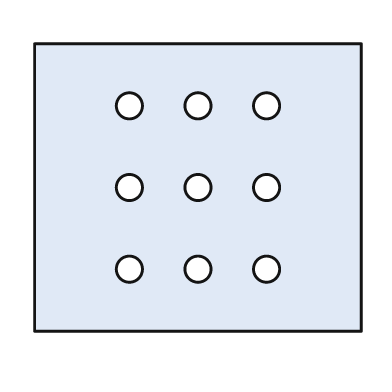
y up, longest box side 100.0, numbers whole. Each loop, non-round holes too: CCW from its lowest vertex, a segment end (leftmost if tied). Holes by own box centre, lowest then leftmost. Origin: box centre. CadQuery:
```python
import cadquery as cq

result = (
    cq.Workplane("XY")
    .moveTo(-50.0, -44.0)
    .lineTo(50.0, -44.0)
    .lineTo(50.0, 44.0)
    .lineTo(-50.0, 44.0)
    .close()
    .moveTo(-21.0, -25.0)
    .circle(4.0)
    .moveTo(0.0, -25.0)
    .circle(4.0)
    .moveTo(21.0, -25.0)
    .circle(4.0)
    .moveTo(-21.0, 0.0)
    .circle(4.0)
    .moveTo(0.0, 0.0)
    .circle(4.0)
    .moveTo(21.0, 0.0)
    .circle(4.0)
    .moveTo(-21.0, 25.0)
    .circle(4.0)
    .moveTo(0.0, 25.0)
    .circle(4.0)
    .moveTo(21.0, 25.0)
    .circle(4.0)
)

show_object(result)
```